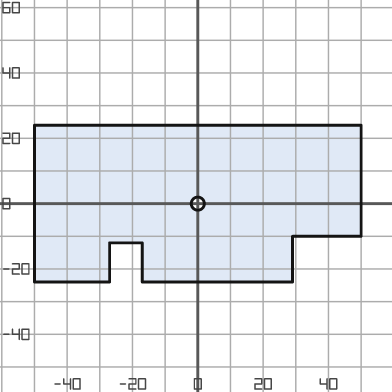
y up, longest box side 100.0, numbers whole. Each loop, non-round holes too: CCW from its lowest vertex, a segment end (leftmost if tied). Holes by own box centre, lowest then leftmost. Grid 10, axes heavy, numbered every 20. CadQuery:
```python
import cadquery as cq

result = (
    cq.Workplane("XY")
    .moveTo(-50.0, -24.0)
    .lineTo(-27.0, -24.0)
    .lineTo(-27.0, -12.0)
    .lineTo(-17.0, -12.0)
    .lineTo(-17.0, -24.0)
    .lineTo(29.0, -24.0)
    .lineTo(29.0, -10.0)
    .lineTo(50.0, -10.0)
    .lineTo(50.0, 24.0)
    .lineTo(-50.0, 24.0)
    .close()
    .moveTo(0.0, 0.0)
    .circle(2.0)
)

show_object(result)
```